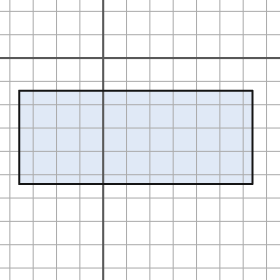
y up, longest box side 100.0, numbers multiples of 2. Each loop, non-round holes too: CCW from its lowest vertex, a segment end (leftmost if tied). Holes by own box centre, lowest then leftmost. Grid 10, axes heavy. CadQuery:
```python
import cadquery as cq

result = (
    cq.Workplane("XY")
    .moveTo(-36.0, -54.0)
    .lineTo(64.0, -54.0)
    .lineTo(64.0, -14.0)
    .lineTo(-36.0, -14.0)
    .close()
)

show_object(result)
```